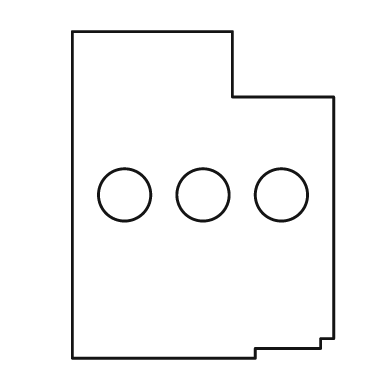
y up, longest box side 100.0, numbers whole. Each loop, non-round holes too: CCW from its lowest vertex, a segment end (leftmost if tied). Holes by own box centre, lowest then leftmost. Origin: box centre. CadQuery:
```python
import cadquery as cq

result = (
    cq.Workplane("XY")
    .moveTo(-40.0, -50.0)
    .lineTo(16.0, -50.0)
    .lineTo(16.0, -47.0)
    .lineTo(36.0, -47.0)
    .lineTo(36.0, -44.0)
    .lineTo(40.0, -44.0)
    .lineTo(40.0, 30.0)
    .lineTo(9.0, 30.0)
    .lineTo(9.0, 50.0)
    .lineTo(-40.0, 50.0)
    .close()
    .moveTo(-24.0, 0.0)
    .circle(8.0)
    .moveTo(0.0, 0.0)
    .circle(8.0)
    .moveTo(24.0, 0.0)
    .circle(8.0)
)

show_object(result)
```